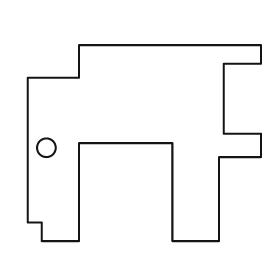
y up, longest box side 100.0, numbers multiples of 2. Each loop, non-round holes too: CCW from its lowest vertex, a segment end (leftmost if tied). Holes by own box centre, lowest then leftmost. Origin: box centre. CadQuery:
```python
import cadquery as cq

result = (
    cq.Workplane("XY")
    .moveTo(-44.0, -42.0)
    .lineTo(-28.0, -42.0)
    .lineTo(-28.0, 0.0)
    .lineTo(12.0, 0.0)
    .lineTo(12.0, -42.0)
    .lineTo(32.0, -42.0)
    .lineTo(32.0, -6.0)
    .lineTo(50.0, -6.0)
    .lineTo(50.0, 4.0)
    .lineTo(34.0, 4.0)
    .lineTo(34.0, 34.0)
    .lineTo(50.0, 34.0)
    .lineTo(50.0, 42.0)
    .lineTo(-28.0, 42.0)
    .lineTo(-28.0, 28.0)
    .lineTo(-50.0, 28.0)
    .lineTo(-50.0, -34.0)
    .lineTo(-44.0, -34.0)
    .close()
    .moveTo(-42.0, -2.0)
    .circle(4.0)
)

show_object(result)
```